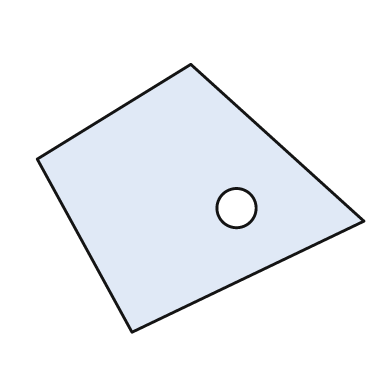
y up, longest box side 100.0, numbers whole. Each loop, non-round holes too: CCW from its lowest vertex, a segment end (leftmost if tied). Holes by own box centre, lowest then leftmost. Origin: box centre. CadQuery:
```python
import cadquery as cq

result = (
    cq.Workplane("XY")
    .moveTo(-21.0, -41.0)
    .lineTo(50.0, -7.0)
    .lineTo(-3.0, 41.0)
    .lineTo(-50.0, 12.0)
    .close()
    .moveTo(11.0, -3.0)
    .circle(6.0)
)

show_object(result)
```